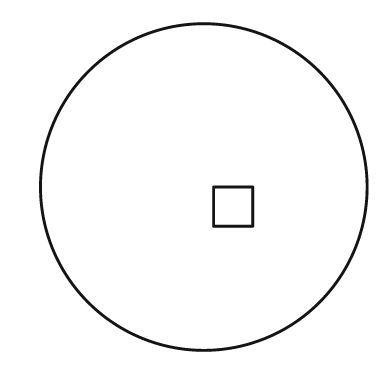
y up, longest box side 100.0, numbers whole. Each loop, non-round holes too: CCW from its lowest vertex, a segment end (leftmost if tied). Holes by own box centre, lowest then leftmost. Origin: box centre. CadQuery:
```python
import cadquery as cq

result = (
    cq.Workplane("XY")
    .moveTo(0.0, 0.0)
    .circle(50.0)
    .moveTo(3.0, -12.0)
    .lineTo(15.0, -12.0)
    .lineTo(15.0, 0.0)
    .lineTo(3.0, 0.0)
    .close()
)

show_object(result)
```